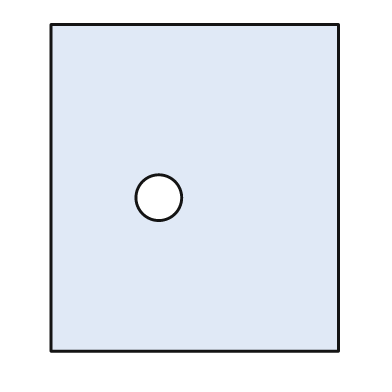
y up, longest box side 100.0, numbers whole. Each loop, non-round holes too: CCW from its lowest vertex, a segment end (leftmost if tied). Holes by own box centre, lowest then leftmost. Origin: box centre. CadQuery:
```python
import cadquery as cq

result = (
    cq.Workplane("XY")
    .moveTo(-44.0, -50.0)
    .lineTo(44.0, -50.0)
    .lineTo(44.0, 50.0)
    .lineTo(-44.0, 50.0)
    .close()
    .moveTo(-11.0, -3.0)
    .circle(7.0)
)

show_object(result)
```